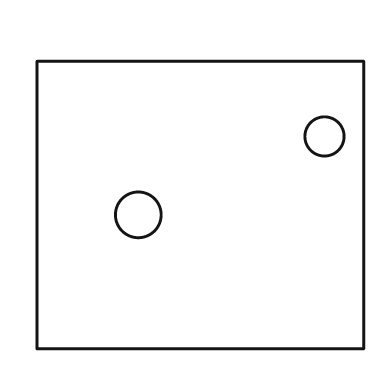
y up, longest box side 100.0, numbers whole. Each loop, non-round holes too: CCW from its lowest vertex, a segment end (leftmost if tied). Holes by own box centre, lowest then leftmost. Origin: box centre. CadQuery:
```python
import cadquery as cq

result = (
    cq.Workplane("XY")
    .moveTo(-50.0, -44.0)
    .lineTo(50.0, -44.0)
    .lineTo(50.0, 44.0)
    .lineTo(-50.0, 44.0)
    .close()
    .moveTo(-19.0, -3.0)
    .circle(7.0)
    .moveTo(38.0, 21.0)
    .circle(6.0)
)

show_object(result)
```